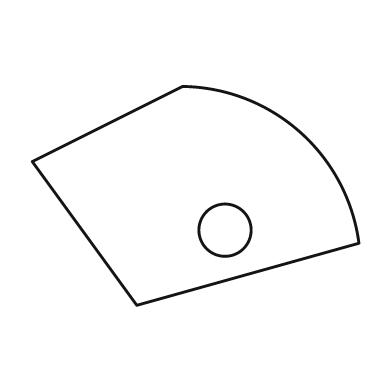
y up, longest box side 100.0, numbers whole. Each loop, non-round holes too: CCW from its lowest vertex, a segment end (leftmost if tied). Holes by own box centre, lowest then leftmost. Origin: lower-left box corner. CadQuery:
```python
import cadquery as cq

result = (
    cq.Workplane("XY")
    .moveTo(32.0, 0.0)
    .lineTo(100.0, 19.0)
    .threePointArc((82.0, 53.0), (46.0, 67.0))
    .lineTo(0.0, 44.0)
    .close()
    .moveTo(59.0, 23.0)
    .circle(8.0)
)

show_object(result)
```